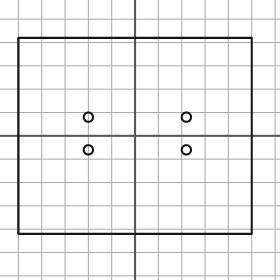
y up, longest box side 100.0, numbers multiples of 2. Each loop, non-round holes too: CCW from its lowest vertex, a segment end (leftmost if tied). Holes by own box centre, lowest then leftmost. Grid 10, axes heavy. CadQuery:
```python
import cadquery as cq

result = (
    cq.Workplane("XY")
    .moveTo(-50.0, -42.0)
    .lineTo(50.0, -42.0)
    .lineTo(50.0, 42.0)
    .lineTo(-50.0, 42.0)
    .close()
    .moveTo(-20.0, -6.0)
    .circle(2.0)
    .moveTo(22.0, -6.0)
    .circle(2.0)
    .moveTo(-20.0, 8.0)
    .circle(2.0)
    .moveTo(22.0, 8.0)
    .circle(2.0)
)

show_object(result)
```